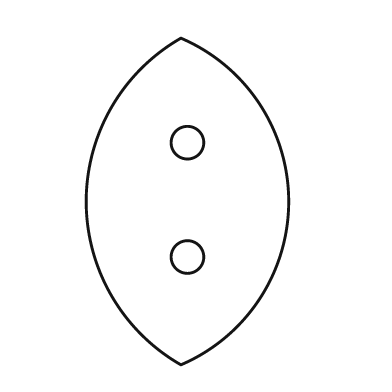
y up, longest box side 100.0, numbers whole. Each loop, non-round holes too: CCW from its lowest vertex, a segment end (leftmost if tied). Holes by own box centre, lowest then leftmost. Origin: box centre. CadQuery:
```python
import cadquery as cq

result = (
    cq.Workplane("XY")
    .moveTo(-2.0, -50.0)
    .threePointArc((31.0, 0.0), (-2.0, 50.0))
    .threePointArc((-31.0, 0.0), (-2.0, -50.0))
    .close()
    .moveTo(0.0, -17.0)
    .circle(5.0)
    .moveTo(0.0, 18.0)
    .circle(5.0)
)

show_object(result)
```